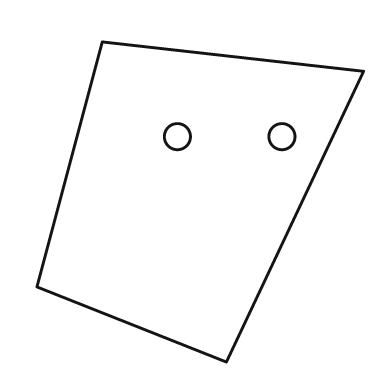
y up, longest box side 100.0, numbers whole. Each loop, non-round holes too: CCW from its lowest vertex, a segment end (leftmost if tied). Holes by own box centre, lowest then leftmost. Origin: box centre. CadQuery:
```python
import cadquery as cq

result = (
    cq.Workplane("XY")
    .moveTo(8.0, -49.0)
    .lineTo(50.0, 40.0)
    .lineTo(-30.0, 49.0)
    .lineTo(-50.0, -26.0)
    .close()
    .moveTo(-7.0, 20.0)
    .circle(4.0)
    .moveTo(25.0, 20.0)
    .circle(4.0)
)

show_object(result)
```